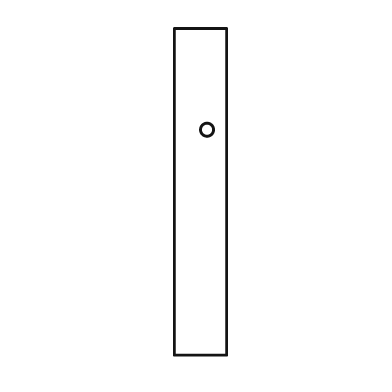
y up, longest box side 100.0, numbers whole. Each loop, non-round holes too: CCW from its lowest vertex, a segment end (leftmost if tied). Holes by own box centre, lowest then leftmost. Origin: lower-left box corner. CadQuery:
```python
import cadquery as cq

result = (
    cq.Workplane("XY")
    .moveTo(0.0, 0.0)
    .lineTo(16.0, 0.0)
    .lineTo(16.0, 100.0)
    .lineTo(0.0, 100.0)
    .close()
    .moveTo(10.0, 69.0)
    .circle(2.0)
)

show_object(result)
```